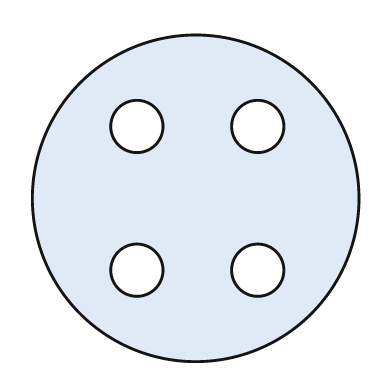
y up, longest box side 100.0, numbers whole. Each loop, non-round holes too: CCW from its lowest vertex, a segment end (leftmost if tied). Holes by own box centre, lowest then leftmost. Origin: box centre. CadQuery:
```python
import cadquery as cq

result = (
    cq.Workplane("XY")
    .moveTo(0.0, 0.0)
    .circle(50.0)
    .moveTo(-18.0, -22.0)
    .circle(8.0)
    .moveTo(19.0, -22.0)
    .circle(8.0)
    .moveTo(-18.0, 22.0)
    .circle(8.0)
    .moveTo(19.0, 22.0)
    .circle(8.0)
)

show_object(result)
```